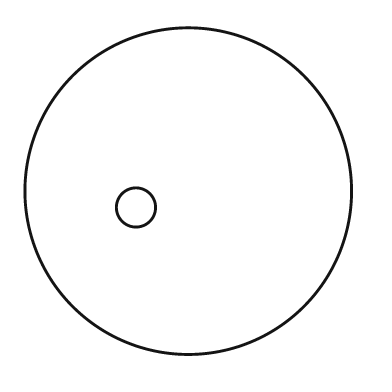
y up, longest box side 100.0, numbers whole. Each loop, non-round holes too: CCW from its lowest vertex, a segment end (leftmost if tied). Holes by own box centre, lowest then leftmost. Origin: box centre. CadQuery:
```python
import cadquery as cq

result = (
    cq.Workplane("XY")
    .moveTo(0.0, 0.0)
    .circle(50.0)
    .moveTo(-16.0, -5.0)
    .circle(6.0)
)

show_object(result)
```